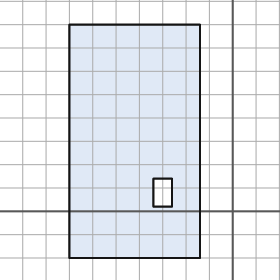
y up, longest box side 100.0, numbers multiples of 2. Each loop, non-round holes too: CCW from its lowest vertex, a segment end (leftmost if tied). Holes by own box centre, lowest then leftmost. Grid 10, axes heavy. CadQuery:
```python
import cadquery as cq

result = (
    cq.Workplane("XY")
    .moveTo(-70.0, -20.0)
    .lineTo(-14.0, -20.0)
    .lineTo(-14.0, 80.0)
    .lineTo(-70.0, 80.0)
    .close()
    .moveTo(-34.0, 2.0)
    .lineTo(-26.0, 2.0)
    .lineTo(-26.0, 14.0)
    .lineTo(-34.0, 14.0)
    .close()
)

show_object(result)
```